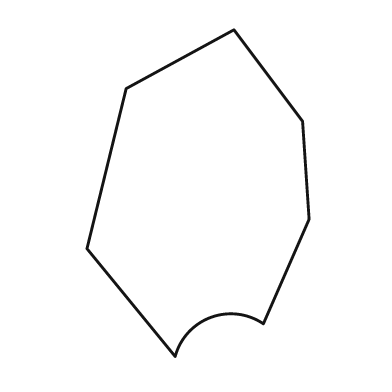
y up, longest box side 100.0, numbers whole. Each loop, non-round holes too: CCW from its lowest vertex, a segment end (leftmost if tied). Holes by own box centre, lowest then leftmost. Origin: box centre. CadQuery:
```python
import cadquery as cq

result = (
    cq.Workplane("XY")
    .moveTo(-7.0, -50.0)
    .threePointArc((4.0, -38.0), (20.0, -40.0))
    .lineTo(34.0, -8.0)
    .lineTo(32.0, 22.0)
    .lineTo(11.0, 50.0)
    .lineTo(-22.0, 32.0)
    .lineTo(-34.0, -17.0)
    .close()
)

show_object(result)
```